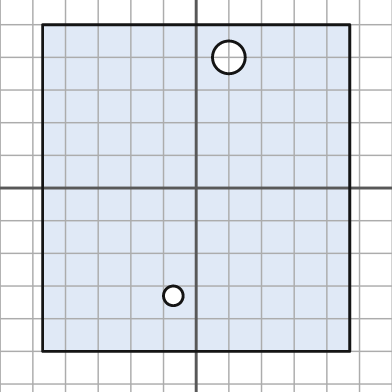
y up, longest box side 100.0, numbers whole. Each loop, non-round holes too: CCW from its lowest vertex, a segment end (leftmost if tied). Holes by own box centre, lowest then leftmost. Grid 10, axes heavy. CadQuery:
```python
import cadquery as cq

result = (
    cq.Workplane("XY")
    .moveTo(-47.0, -50.0)
    .lineTo(47.0, -50.0)
    .lineTo(47.0, 50.0)
    .lineTo(-47.0, 50.0)
    .close()
    .moveTo(-7.0, -33.0)
    .circle(3.0)
    .moveTo(10.0, 40.0)
    .circle(5.0)
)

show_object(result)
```